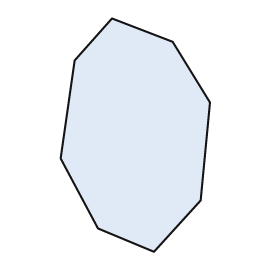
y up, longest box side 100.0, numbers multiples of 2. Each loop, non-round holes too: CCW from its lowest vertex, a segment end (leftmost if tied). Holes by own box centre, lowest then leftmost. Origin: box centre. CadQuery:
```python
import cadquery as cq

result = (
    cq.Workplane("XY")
    .moveTo(8.0, -50.0)
    .lineTo(28.0, -28.0)
    .lineTo(32.0, 14.0)
    .lineTo(16.0, 40.0)
    .lineTo(-10.0, 50.0)
    .lineTo(-26.0, 32.0)
    .lineTo(-32.0, -10.0)
    .lineTo(-16.0, -40.0)
    .close()
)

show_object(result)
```